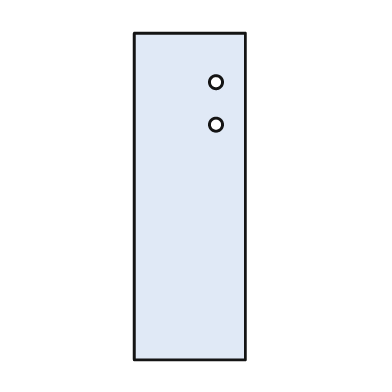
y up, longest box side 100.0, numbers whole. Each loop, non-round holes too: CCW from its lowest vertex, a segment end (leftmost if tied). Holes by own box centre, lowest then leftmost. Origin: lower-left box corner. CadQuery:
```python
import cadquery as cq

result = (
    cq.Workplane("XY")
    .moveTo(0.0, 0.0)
    .lineTo(34.0, 0.0)
    .lineTo(34.0, 100.0)
    .lineTo(0.0, 100.0)
    .close()
    .moveTo(25.0, 72.0)
    .circle(2.0)
    .moveTo(25.0, 85.0)
    .circle(2.0)
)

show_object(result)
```